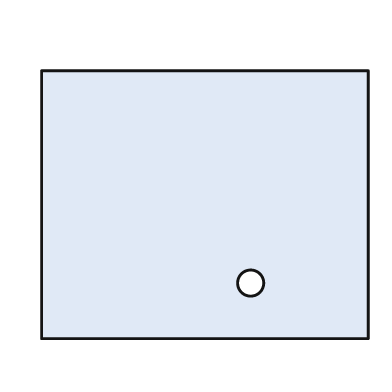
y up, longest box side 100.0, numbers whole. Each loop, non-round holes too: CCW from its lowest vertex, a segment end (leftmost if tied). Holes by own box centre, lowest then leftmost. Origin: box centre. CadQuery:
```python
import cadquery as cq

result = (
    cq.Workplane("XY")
    .moveTo(-50.0, -41.0)
    .lineTo(50.0, -41.0)
    .lineTo(50.0, 41.0)
    .lineTo(-50.0, 41.0)
    .close()
    .moveTo(14.0, -24.0)
    .circle(4.0)
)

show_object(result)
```